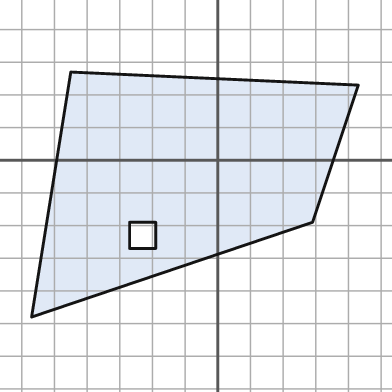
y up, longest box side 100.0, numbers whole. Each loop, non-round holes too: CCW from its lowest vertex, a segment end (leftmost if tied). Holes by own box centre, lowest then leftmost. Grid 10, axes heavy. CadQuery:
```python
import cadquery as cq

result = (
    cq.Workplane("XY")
    .moveTo(-57.0, -48.0)
    .lineTo(29.0, -19.0)
    .lineTo(43.0, 23.0)
    .lineTo(-45.0, 27.0)
    .close()
    .moveTo(-27.0, -27.0)
    .lineTo(-19.0, -27.0)
    .lineTo(-19.0, -19.0)
    .lineTo(-27.0, -19.0)
    .close()
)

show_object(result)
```